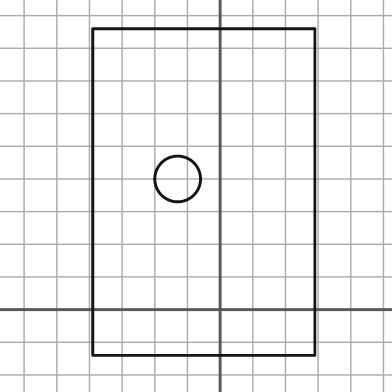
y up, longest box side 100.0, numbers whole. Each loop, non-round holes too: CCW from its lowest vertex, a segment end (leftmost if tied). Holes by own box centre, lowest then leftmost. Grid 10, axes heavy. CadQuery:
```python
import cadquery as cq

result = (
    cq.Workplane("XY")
    .moveTo(-39.0, -14.0)
    .lineTo(29.0, -14.0)
    .lineTo(29.0, 86.0)
    .lineTo(-39.0, 86.0)
    .close()
    .moveTo(-13.0, 40.0)
    .circle(7.0)
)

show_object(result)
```